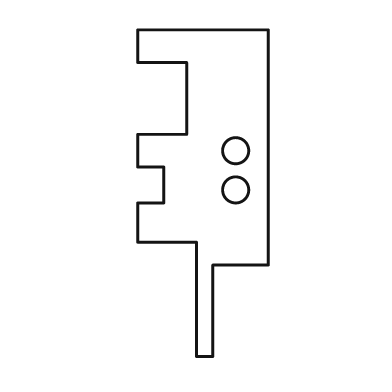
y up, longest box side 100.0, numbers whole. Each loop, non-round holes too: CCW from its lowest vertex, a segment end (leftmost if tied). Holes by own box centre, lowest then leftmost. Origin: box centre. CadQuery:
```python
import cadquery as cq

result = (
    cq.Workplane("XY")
    .moveTo(-2.0, -50.0)
    .lineTo(3.0, -50.0)
    .lineTo(3.0, -22.0)
    .lineTo(20.0, -22.0)
    .lineTo(20.0, 50.0)
    .lineTo(-20.0, 50.0)
    .lineTo(-20.0, 40.0)
    .lineTo(-5.0, 40.0)
    .lineTo(-5.0, 18.0)
    .lineTo(-20.0, 18.0)
    .lineTo(-20.0, 8.0)
    .lineTo(-12.0, 8.0)
    .lineTo(-12.0, -3.0)
    .lineTo(-20.0, -3.0)
    .lineTo(-20.0, -15.0)
    .lineTo(-2.0, -15.0)
    .close()
    .moveTo(10.0, 1.0)
    .circle(4.0)
    .moveTo(10.0, 13.0)
    .circle(4.0)
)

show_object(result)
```